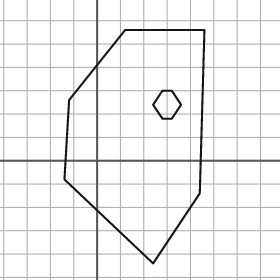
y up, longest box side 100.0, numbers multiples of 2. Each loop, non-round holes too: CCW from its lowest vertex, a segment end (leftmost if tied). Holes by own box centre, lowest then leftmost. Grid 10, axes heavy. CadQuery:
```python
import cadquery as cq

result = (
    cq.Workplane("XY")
    .moveTo(24.0, -44.0)
    .lineTo(44.0, -14.0)
    .lineTo(46.0, 56.0)
    .lineTo(12.0, 56.0)
    .lineTo(-12.0, 26.0)
    .lineTo(-14.0, -8.0)
    .close()
    .moveTo(28.0, 18.0)
    .lineTo(32.0, 18.0)
    .lineTo(36.0, 24.0)
    .lineTo(32.0, 30.0)
    .lineTo(28.0, 30.0)
    .lineTo(24.0, 24.0)
    .close()
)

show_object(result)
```